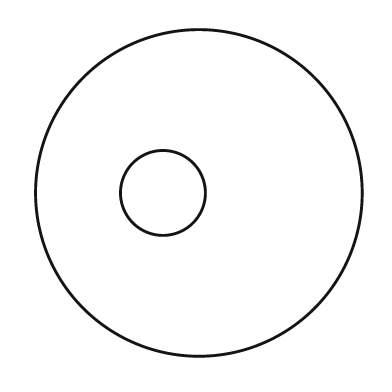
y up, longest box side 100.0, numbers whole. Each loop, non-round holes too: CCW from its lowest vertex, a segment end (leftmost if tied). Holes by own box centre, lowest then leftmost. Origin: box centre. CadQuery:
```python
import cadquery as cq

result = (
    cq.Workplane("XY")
    .moveTo(0.0, 0.0)
    .circle(50.0)
    .moveTo(-11.0, 0.0)
    .circle(13.0)
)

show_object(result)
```